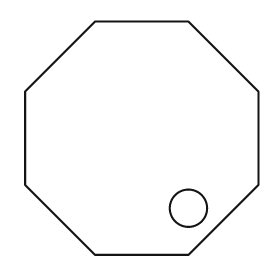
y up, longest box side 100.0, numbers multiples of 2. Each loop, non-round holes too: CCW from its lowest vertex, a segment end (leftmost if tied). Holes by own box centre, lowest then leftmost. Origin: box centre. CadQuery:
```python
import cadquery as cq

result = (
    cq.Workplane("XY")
    .moveTo(-20.0, -50.0)
    .lineTo(20.0, -50.0)
    .lineTo(50.0, -20.0)
    .lineTo(50.0, 20.0)
    .lineTo(20.0, 50.0)
    .lineTo(-20.0, 50.0)
    .lineTo(-50.0, 20.0)
    .lineTo(-50.0, -20.0)
    .close()
    .moveTo(20.0, -30.0)
    .circle(8.0)
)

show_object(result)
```